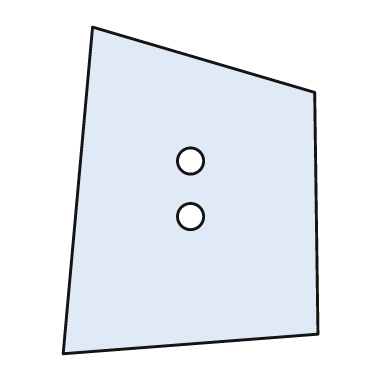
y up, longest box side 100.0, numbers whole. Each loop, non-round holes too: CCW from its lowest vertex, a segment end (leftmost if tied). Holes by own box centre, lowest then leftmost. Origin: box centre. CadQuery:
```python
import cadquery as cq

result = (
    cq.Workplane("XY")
    .moveTo(-39.0, -50.0)
    .lineTo(39.0, -44.0)
    .lineTo(38.0, 30.0)
    .lineTo(-30.0, 50.0)
    .close()
    .moveTo(0.0, -8.0)
    .circle(4.0)
    .moveTo(0.0, 9.0)
    .circle(4.0)
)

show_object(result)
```